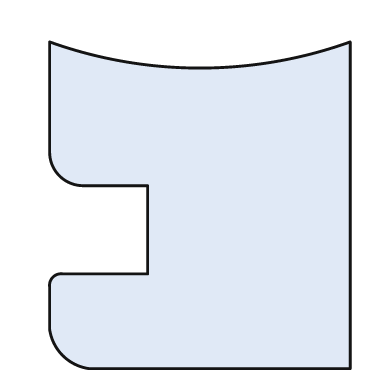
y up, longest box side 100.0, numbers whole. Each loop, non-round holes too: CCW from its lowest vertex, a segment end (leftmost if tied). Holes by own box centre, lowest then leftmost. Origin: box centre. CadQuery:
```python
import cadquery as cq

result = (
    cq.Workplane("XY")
    .moveTo(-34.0, -50.0)
    .lineTo(46.0, -50.0)
    .lineTo(46.0, 50.0)
    .threePointArc((0.0, 42.0), (-46.0, 50.0))
    .lineTo(-46.0, 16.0)
    .threePointArc((-43.0, 9.0), (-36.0, 6.0))
    .lineTo(-16.0, 6.0)
    .lineTo(-16.0, -21.0)
    .lineTo(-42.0, -21.0)
    .threePointArc((-45.0, -22.0), (-46.0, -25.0))
    .lineTo(-46.0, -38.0)
    .threePointArc((-42.0, -46.0), (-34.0, -50.0))
    .close()
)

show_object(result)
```